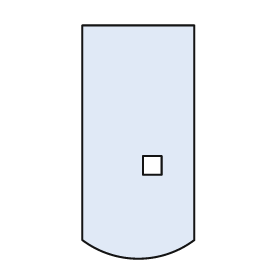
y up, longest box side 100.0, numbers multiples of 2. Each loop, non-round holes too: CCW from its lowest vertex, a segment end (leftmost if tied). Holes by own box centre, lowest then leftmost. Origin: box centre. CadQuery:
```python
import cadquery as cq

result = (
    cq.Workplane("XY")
    .moveTo(-24.0, -42.0)
    .threePointArc((0.0, -50.0), (24.0, -42.0))
    .lineTo(24.0, 50.0)
    .lineTo(-24.0, 50.0)
    .close()
    .moveTo(2.0, -14.0)
    .lineTo(10.0, -14.0)
    .lineTo(10.0, -6.0)
    .lineTo(2.0, -6.0)
    .close()
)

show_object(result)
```